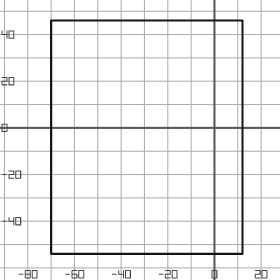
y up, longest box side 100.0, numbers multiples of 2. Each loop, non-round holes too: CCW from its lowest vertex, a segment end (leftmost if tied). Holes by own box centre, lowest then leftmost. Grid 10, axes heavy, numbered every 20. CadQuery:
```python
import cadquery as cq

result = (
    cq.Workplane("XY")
    .moveTo(-70.0, -54.0)
    .lineTo(12.0, -54.0)
    .lineTo(12.0, 46.0)
    .lineTo(-70.0, 46.0)
    .close()
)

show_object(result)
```